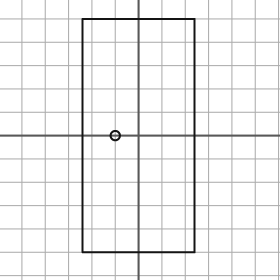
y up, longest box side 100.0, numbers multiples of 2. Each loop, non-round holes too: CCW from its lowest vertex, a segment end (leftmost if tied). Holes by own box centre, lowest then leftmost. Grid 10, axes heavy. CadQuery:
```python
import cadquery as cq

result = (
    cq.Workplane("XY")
    .moveTo(-24.0, -50.0)
    .lineTo(24.0, -50.0)
    .lineTo(24.0, 50.0)
    .lineTo(-24.0, 50.0)
    .close()
    .moveTo(-10.0, 0.0)
    .circle(2.0)
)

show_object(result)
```